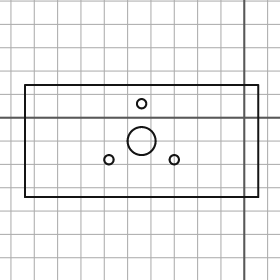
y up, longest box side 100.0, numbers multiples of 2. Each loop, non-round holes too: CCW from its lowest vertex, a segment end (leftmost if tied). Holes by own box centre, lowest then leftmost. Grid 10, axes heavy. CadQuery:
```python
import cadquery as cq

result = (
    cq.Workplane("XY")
    .moveTo(-94.0, -34.0)
    .lineTo(6.0, -34.0)
    .lineTo(6.0, 14.0)
    .lineTo(-94.0, 14.0)
    .close()
    .moveTo(-58.0, -18.0)
    .circle(2.0)
    .moveTo(-30.0, -18.0)
    .circle(2.0)
    .moveTo(-44.0, -10.0)
    .circle(6.0)
    .moveTo(-44.0, 6.0)
    .circle(2.0)
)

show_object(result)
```